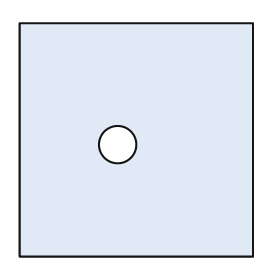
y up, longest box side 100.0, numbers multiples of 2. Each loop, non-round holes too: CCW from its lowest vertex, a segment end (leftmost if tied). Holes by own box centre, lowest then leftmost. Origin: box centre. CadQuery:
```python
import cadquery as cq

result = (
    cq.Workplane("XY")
    .moveTo(-50.0, -50.0)
    .lineTo(50.0, -50.0)
    .lineTo(50.0, 50.0)
    .lineTo(-50.0, 50.0)
    .close()
    .moveTo(-8.0, -2.0)
    .circle(8.0)
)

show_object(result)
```